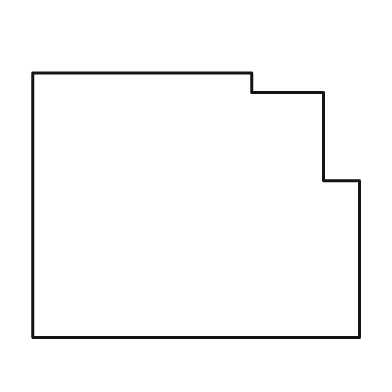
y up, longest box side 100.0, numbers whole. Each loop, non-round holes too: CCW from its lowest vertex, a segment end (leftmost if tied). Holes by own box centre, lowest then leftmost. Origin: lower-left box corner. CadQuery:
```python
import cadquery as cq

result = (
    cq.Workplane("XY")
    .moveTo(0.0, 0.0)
    .lineTo(100.0, 0.0)
    .lineTo(100.0, 48.0)
    .lineTo(89.0, 48.0)
    .lineTo(89.0, 75.0)
    .lineTo(67.0, 75.0)
    .lineTo(67.0, 81.0)
    .lineTo(0.0, 81.0)
    .close()
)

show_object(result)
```